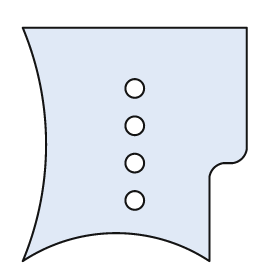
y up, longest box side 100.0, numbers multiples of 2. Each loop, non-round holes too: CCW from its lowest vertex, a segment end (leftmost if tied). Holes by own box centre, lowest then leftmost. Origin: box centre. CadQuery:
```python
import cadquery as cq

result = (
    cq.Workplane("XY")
    .moveTo(-48.0, -50.0)
    .threePointArc((-8.0, -38.0), (32.0, -50.0))
    .lineTo(32.0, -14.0)
    .threePointArc((34.0, -10.0), (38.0, -8.0))
    .lineTo(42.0, -8.0)
    .threePointArc((46.0, -6.0), (48.0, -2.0))
    .lineTo(48.0, 50.0)
    .lineTo(-48.0, 50.0)
    .threePointArc((-38.0, 0.0), (-48.0, -50.0))
    .close()
    .moveTo(0.0, -24.0)
    .circle(4.0)
    .moveTo(0.0, -8.0)
    .circle(4.0)
    .moveTo(0.0, 8.0)
    .circle(4.0)
    .moveTo(0.0, 24.0)
    .circle(4.0)
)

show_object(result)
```